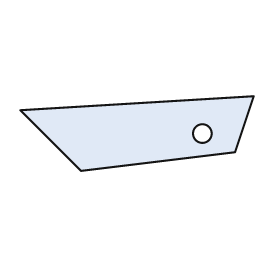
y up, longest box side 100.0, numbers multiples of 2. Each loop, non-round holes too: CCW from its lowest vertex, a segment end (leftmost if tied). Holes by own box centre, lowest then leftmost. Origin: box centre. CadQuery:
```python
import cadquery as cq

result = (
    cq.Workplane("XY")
    .moveTo(-24.0, -16.0)
    .lineTo(42.0, -8.0)
    .lineTo(50.0, 16.0)
    .lineTo(-50.0, 10.0)
    .close()
    .moveTo(28.0, 0.0)
    .circle(4.0)
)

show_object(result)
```